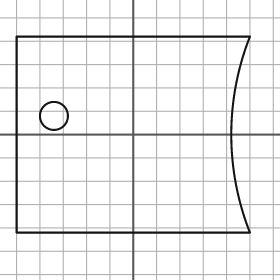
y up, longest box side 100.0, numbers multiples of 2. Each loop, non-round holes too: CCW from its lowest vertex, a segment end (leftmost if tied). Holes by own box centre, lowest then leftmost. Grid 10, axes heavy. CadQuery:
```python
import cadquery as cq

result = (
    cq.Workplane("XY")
    .moveTo(-50.0, -42.0)
    .lineTo(50.0, -42.0)
    .threePointArc((42.0, 0.0), (50.0, 42.0))
    .lineTo(-50.0, 42.0)
    .close()
    .moveTo(-34.0, 8.0)
    .circle(6.0)
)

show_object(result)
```